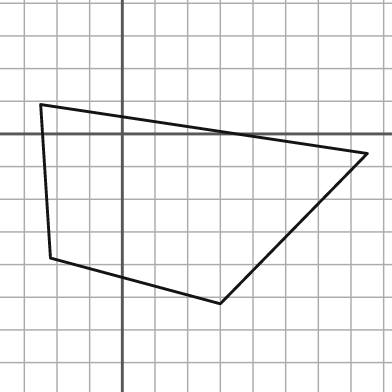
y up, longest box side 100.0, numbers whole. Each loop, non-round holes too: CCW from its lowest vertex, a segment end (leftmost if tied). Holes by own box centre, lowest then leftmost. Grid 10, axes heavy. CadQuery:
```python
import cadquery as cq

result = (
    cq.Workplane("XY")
    .moveTo(30.0, -52.0)
    .lineTo(75.0, -6.0)
    .lineTo(-25.0, 9.0)
    .lineTo(-22.0, -38.0)
    .close()
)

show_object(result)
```